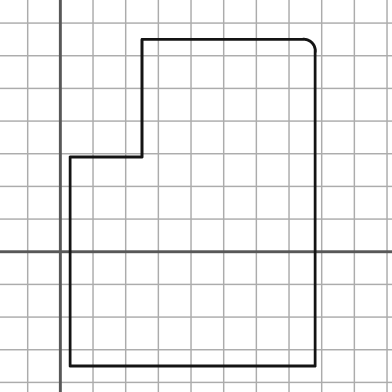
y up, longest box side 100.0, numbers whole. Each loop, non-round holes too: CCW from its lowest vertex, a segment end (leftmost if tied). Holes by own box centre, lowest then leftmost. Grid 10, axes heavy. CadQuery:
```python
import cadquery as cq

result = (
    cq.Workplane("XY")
    .moveTo(3.0, -35.0)
    .lineTo(78.0, -35.0)
    .lineTo(78.0, 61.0)
    .threePointArc((77.0, 64.0), (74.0, 65.0))
    .lineTo(25.0, 65.0)
    .lineTo(25.0, 29.0)
    .lineTo(3.0, 29.0)
    .close()
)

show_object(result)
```